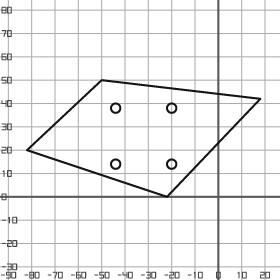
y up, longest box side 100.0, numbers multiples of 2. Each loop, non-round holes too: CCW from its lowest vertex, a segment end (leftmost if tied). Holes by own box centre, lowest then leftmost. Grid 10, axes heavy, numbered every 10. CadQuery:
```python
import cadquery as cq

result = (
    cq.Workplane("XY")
    .moveTo(-22.0, 0.0)
    .lineTo(18.0, 42.0)
    .lineTo(-50.0, 50.0)
    .lineTo(-82.0, 20.0)
    .close()
    .moveTo(-44.0, 14.0)
    .circle(2.0)
    .moveTo(-20.0, 14.0)
    .circle(2.0)
    .moveTo(-44.0, 38.0)
    .circle(2.0)
    .moveTo(-20.0, 38.0)
    .circle(2.0)
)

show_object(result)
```